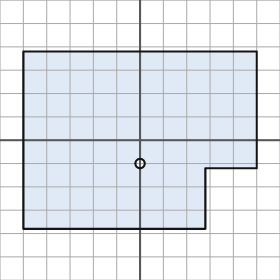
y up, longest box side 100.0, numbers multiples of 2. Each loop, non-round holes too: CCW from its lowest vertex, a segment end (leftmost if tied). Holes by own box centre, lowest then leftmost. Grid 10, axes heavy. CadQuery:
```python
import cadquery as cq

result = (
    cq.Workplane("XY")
    .moveTo(-50.0, -38.0)
    .lineTo(28.0, -38.0)
    .lineTo(28.0, -12.0)
    .lineTo(50.0, -12.0)
    .lineTo(50.0, 38.0)
    .lineTo(-50.0, 38.0)
    .close()
    .moveTo(0.0, -10.0)
    .circle(2.0)
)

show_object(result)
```